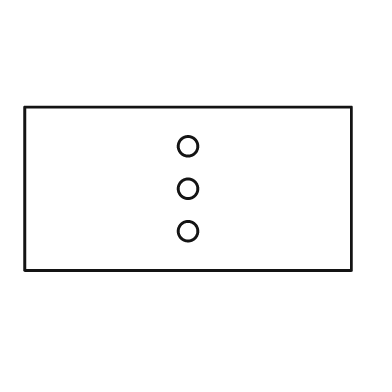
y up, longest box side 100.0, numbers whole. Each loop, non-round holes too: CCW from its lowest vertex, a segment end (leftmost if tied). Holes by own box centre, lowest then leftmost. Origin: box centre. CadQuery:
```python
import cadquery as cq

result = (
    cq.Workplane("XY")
    .moveTo(-50.0, -25.0)
    .lineTo(50.0, -25.0)
    .lineTo(50.0, 25.0)
    .lineTo(-50.0, 25.0)
    .close()
    .moveTo(0.0, -13.0)
    .circle(3.0)
    .moveTo(0.0, 0.0)
    .circle(3.0)
    .moveTo(0.0, 13.0)
    .circle(3.0)
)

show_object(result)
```